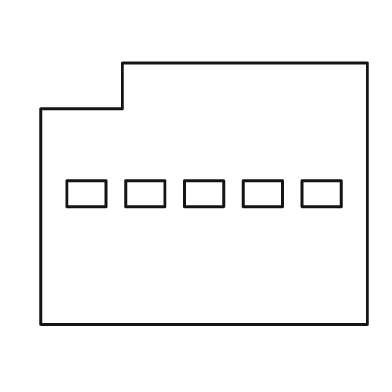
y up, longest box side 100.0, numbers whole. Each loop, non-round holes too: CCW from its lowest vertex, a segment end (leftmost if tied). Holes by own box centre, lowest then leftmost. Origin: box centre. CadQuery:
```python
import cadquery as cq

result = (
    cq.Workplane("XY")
    .moveTo(-50.0, -40.0)
    .lineTo(50.0, -40.0)
    .lineTo(50.0, 40.0)
    .lineTo(-25.0, 40.0)
    .lineTo(-25.0, 26.0)
    .lineTo(-50.0, 26.0)
    .close()
    .moveTo(-42.0, -4.0)
    .lineTo(-30.0, -4.0)
    .lineTo(-30.0, 4.0)
    .lineTo(-42.0, 4.0)
    .close()
    .moveTo(-24.0, -4.0)
    .lineTo(-12.0, -4.0)
    .lineTo(-12.0, 4.0)
    .lineTo(-24.0, 4.0)
    .close()
    .moveTo(-6.0, -4.0)
    .lineTo(6.0, -4.0)
    .lineTo(6.0, 4.0)
    .lineTo(-6.0, 4.0)
    .close()
    .moveTo(12.0, -4.0)
    .lineTo(24.0, -4.0)
    .lineTo(24.0, 4.0)
    .lineTo(12.0, 4.0)
    .close()
    .moveTo(30.0, -4.0)
    .lineTo(42.0, -4.0)
    .lineTo(42.0, 4.0)
    .lineTo(30.0, 4.0)
    .close()
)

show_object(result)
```